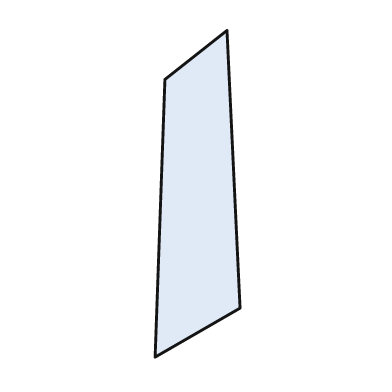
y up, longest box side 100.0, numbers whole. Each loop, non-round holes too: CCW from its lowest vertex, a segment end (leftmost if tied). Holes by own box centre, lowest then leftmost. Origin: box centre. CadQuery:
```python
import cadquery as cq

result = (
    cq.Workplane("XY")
    .moveTo(-13.0, -50.0)
    .lineTo(13.0, -35.0)
    .lineTo(9.0, 50.0)
    .lineTo(-10.0, 35.0)
    .close()
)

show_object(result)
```